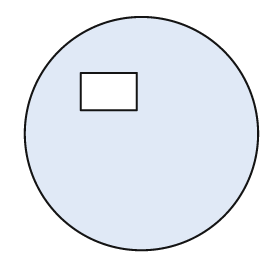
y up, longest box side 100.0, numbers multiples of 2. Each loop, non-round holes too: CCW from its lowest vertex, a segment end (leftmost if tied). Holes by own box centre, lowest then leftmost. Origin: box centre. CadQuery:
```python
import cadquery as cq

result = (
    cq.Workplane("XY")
    .moveTo(0.0, 0.0)
    .circle(50.0)
    .moveTo(-26.0, 10.0)
    .lineTo(-2.0, 10.0)
    .lineTo(-2.0, 26.0)
    .lineTo(-26.0, 26.0)
    .close()
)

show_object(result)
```